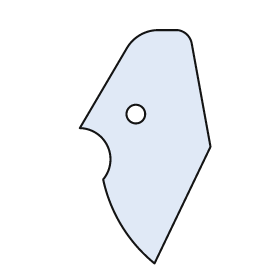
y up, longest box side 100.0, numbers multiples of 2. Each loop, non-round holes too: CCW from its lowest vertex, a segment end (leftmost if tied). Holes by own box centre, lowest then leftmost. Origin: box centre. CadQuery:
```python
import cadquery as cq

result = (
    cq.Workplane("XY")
    .moveTo(4.0, -50.0)
    .lineTo(28.0, 0.0)
    .lineTo(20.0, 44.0)
    .threePointArc((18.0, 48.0), (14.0, 50.0))
    .lineTo(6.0, 50.0)
    .threePointArc((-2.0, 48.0), (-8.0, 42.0))
    .lineTo(-28.0, 8.0)
    .threePointArc((-16.0, 0.0), (-18.0, -14.0))
    .threePointArc((-10.0, -34.0), (4.0, -50.0))
    .close()
    .moveTo(-4.0, 14.0)
    .circle(4.0)
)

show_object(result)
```